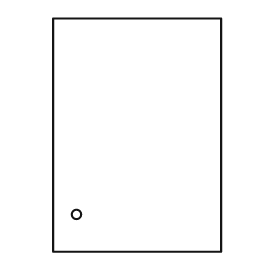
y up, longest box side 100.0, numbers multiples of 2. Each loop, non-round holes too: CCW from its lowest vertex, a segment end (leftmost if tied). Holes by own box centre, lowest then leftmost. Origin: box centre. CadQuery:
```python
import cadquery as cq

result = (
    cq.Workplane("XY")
    .moveTo(-36.0, -50.0)
    .lineTo(36.0, -50.0)
    .lineTo(36.0, 50.0)
    .lineTo(-36.0, 50.0)
    .close()
    .moveTo(-26.0, -34.0)
    .circle(2.0)
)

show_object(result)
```